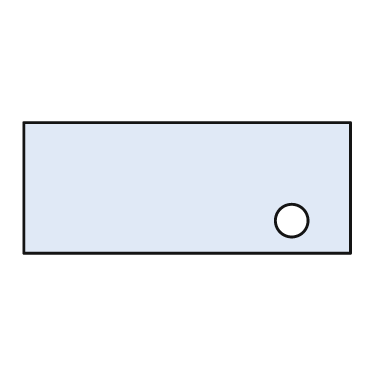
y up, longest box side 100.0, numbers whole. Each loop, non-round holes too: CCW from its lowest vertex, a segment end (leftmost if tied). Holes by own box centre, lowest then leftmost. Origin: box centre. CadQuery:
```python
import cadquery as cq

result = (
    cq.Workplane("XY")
    .moveTo(-50.0, -20.0)
    .lineTo(50.0, -20.0)
    .lineTo(50.0, 20.0)
    .lineTo(-50.0, 20.0)
    .close()
    .moveTo(32.0, -10.0)
    .circle(5.0)
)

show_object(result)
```